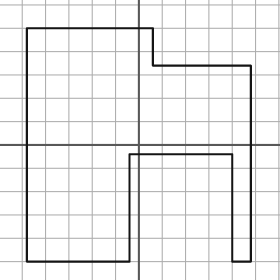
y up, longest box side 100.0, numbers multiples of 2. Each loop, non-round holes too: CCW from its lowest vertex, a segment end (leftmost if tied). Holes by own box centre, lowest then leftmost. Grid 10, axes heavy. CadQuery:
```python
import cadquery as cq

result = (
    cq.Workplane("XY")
    .moveTo(-48.0, -50.0)
    .lineTo(-4.0, -50.0)
    .lineTo(-4.0, -4.0)
    .lineTo(40.0, -4.0)
    .lineTo(40.0, -50.0)
    .lineTo(48.0, -50.0)
    .lineTo(48.0, 34.0)
    .lineTo(6.0, 34.0)
    .lineTo(6.0, 50.0)
    .lineTo(-48.0, 50.0)
    .close()
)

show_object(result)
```